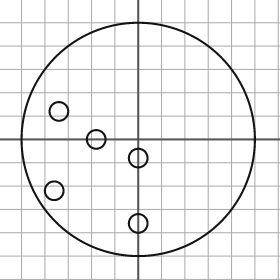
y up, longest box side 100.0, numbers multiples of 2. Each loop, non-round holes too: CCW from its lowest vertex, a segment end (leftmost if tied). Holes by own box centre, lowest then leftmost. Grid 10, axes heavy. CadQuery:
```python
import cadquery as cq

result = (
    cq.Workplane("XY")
    .moveTo(0.0, 0.0)
    .circle(50.0)
    .moveTo(0.0, -36.0)
    .circle(4.0)
    .moveTo(-36.0, -22.0)
    .circle(4.0)
    .moveTo(0.0, -8.0)
    .circle(4.0)
    .moveTo(-18.0, 0.0)
    .circle(4.0)
    .moveTo(-34.0, 12.0)
    .circle(4.0)
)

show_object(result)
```